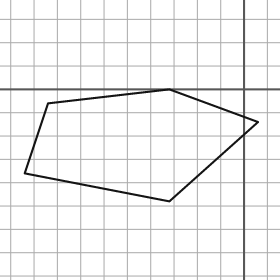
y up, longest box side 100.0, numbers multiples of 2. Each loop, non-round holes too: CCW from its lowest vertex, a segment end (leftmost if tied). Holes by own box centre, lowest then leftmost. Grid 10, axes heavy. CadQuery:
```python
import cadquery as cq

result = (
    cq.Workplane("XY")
    .moveTo(-32.0, -48.0)
    .lineTo(6.0, -14.0)
    .lineTo(-32.0, 0.0)
    .lineTo(-84.0, -6.0)
    .lineTo(-94.0, -36.0)
    .close()
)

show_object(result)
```